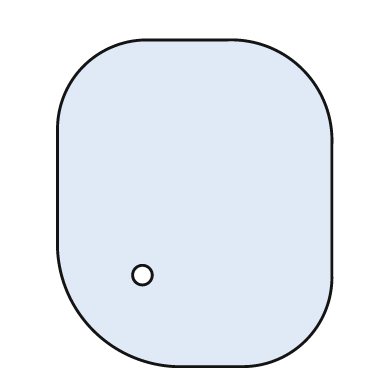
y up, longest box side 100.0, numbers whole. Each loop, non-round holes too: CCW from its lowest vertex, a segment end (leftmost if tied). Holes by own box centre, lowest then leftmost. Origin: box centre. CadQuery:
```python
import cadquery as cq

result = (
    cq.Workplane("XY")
    .moveTo(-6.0, -50.0)
    .lineTo(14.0, -50.0)
    .threePointArc((34.0, -42.0), (42.0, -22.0))
    .lineTo(42.0, 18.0)
    .threePointArc((33.0, 41.0), (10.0, 50.0))
    .lineTo(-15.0, 50.0)
    .threePointArc((-34.0, 42.0), (-42.0, 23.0))
    .lineTo(-42.0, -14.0)
    .threePointArc((-31.0, -39.0), (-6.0, -50.0))
    .close()
    .moveTo(-16.0, -22.0)
    .circle(3.0)
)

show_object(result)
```